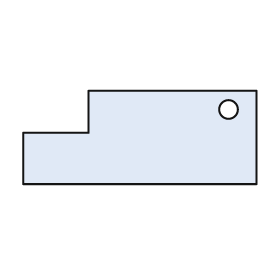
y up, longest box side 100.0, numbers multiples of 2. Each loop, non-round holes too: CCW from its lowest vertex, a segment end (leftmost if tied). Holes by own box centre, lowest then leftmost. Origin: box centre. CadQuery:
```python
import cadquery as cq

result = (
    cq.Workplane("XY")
    .moveTo(-50.0, -20.0)
    .lineTo(50.0, -20.0)
    .lineTo(50.0, 20.0)
    .lineTo(-22.0, 20.0)
    .lineTo(-22.0, 2.0)
    .lineTo(-50.0, 2.0)
    .close()
    .moveTo(38.0, 12.0)
    .circle(4.0)
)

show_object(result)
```